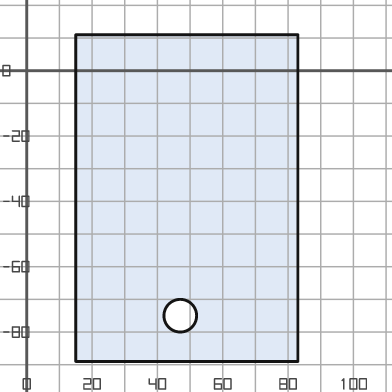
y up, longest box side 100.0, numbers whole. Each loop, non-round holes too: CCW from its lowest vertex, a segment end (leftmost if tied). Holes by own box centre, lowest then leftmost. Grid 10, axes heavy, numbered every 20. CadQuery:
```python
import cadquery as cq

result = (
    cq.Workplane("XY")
    .moveTo(15.0, -89.0)
    .lineTo(83.0, -89.0)
    .lineTo(83.0, 11.0)
    .lineTo(15.0, 11.0)
    .close()
    .moveTo(47.0, -75.0)
    .circle(5.0)
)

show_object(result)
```